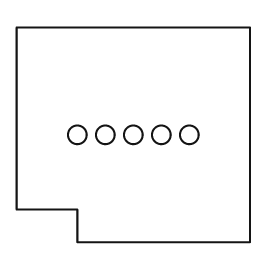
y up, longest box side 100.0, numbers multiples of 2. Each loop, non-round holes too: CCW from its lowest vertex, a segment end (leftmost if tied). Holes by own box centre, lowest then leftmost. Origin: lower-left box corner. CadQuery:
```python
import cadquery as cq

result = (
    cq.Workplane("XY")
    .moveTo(26.0, 0.0)
    .lineTo(100.0, 0.0)
    .lineTo(100.0, 92.0)
    .lineTo(0.0, 92.0)
    .lineTo(0.0, 14.0)
    .lineTo(26.0, 14.0)
    .close()
    .moveTo(26.0, 46.0)
    .circle(4.0)
    .moveTo(38.0, 46.0)
    .circle(4.0)
    .moveTo(50.0, 46.0)
    .circle(4.0)
    .moveTo(62.0, 46.0)
    .circle(4.0)
    .moveTo(74.0, 46.0)
    .circle(4.0)
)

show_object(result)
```